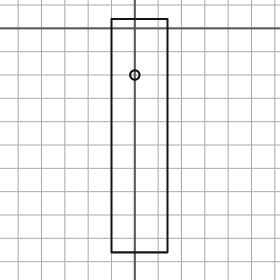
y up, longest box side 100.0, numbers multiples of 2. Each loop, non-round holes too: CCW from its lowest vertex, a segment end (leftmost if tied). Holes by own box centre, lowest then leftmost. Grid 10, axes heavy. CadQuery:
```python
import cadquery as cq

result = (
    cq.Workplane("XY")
    .moveTo(-10.0, -96.0)
    .lineTo(14.0, -96.0)
    .lineTo(14.0, 4.0)
    .lineTo(-10.0, 4.0)
    .close()
    .moveTo(0.0, -20.0)
    .circle(2.0)
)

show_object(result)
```